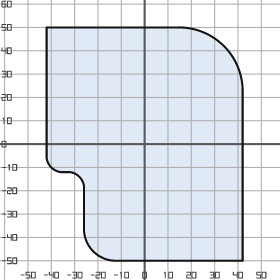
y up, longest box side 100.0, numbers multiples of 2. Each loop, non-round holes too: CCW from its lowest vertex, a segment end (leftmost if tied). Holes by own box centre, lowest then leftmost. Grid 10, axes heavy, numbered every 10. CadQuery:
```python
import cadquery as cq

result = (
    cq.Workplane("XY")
    .moveTo(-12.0, -50.0)
    .lineTo(42.0, -50.0)
    .lineTo(42.0, 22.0)
    .threePointArc((34.0, 42.0), (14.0, 50.0))
    .lineTo(-42.0, 50.0)
    .lineTo(-42.0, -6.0)
    .threePointArc((-40.0, -10.0), (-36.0, -12.0))
    .lineTo(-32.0, -12.0)
    .threePointArc((-28.0, -14.0), (-26.0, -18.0))
    .lineTo(-26.0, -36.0)
    .threePointArc((-22.0, -46.0), (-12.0, -50.0))
    .close()
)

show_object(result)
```